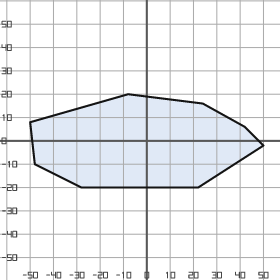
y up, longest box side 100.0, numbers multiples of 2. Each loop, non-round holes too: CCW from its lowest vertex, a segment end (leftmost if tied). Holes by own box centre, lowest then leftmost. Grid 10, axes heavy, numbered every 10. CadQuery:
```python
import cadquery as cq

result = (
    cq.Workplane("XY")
    .moveTo(-28.0, -20.0)
    .lineTo(22.0, -20.0)
    .lineTo(50.0, -2.0)
    .lineTo(42.0, 6.0)
    .lineTo(24.0, 16.0)
    .lineTo(-8.0, 20.0)
    .lineTo(-50.0, 8.0)
    .lineTo(-48.0, -10.0)
    .close()
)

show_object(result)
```